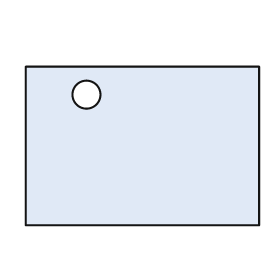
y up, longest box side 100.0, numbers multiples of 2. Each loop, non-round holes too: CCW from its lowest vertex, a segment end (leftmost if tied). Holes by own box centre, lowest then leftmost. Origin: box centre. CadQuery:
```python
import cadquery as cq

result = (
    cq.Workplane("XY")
    .moveTo(-50.0, -34.0)
    .lineTo(50.0, -34.0)
    .lineTo(50.0, 34.0)
    .lineTo(-50.0, 34.0)
    .close()
    .moveTo(-24.0, 22.0)
    .circle(6.0)
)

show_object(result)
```